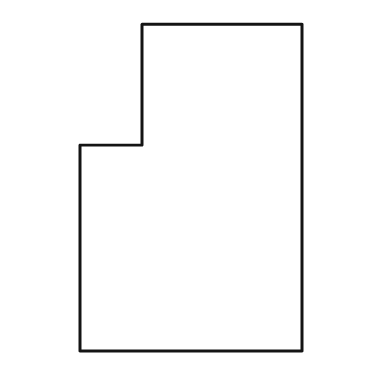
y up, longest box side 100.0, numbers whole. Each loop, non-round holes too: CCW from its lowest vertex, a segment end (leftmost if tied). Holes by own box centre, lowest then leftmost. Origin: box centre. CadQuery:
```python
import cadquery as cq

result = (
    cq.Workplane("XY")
    .moveTo(-34.0, -50.0)
    .lineTo(34.0, -50.0)
    .lineTo(34.0, 50.0)
    .lineTo(-15.0, 50.0)
    .lineTo(-15.0, 13.0)
    .lineTo(-34.0, 13.0)
    .close()
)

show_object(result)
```